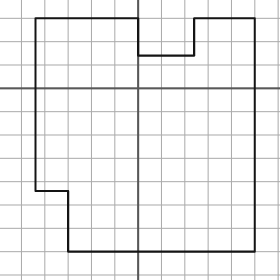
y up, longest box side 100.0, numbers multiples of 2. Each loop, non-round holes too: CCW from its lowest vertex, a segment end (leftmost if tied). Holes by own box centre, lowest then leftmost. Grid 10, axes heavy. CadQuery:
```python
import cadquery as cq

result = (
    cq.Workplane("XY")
    .moveTo(-30.0, -70.0)
    .lineTo(50.0, -70.0)
    .lineTo(50.0, 30.0)
    .lineTo(24.0, 30.0)
    .lineTo(24.0, 14.0)
    .lineTo(0.0, 14.0)
    .lineTo(0.0, 30.0)
    .lineTo(-44.0, 30.0)
    .lineTo(-44.0, -44.0)
    .lineTo(-30.0, -44.0)
    .close()
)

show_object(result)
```